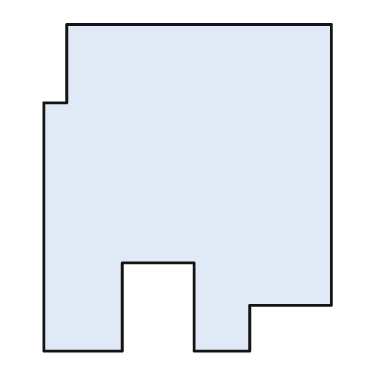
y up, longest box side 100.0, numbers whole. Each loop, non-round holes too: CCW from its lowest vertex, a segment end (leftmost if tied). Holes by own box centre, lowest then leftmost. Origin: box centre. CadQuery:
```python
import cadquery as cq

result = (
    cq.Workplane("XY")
    .moveTo(-44.0, -50.0)
    .lineTo(-20.0, -50.0)
    .lineTo(-20.0, -23.0)
    .lineTo(2.0, -23.0)
    .lineTo(2.0, -50.0)
    .lineTo(19.0, -50.0)
    .lineTo(19.0, -36.0)
    .lineTo(44.0, -36.0)
    .lineTo(44.0, 50.0)
    .lineTo(-37.0, 50.0)
    .lineTo(-37.0, 26.0)
    .lineTo(-44.0, 26.0)
    .close()
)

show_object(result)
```